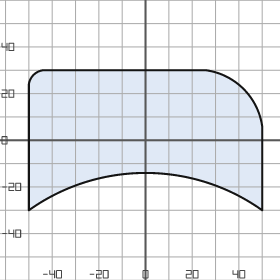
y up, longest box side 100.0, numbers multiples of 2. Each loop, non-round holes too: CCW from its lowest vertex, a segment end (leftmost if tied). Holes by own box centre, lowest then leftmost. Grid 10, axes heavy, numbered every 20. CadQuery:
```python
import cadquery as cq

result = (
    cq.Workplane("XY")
    .moveTo(-50.0, -30.0)
    .threePointArc((0.0, -14.0), (50.0, -30.0))
    .lineTo(50.0, 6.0)
    .threePointArc((42.0, 22.0), (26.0, 30.0))
    .lineTo(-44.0, 30.0)
    .threePointArc((-48.0, 28.0), (-50.0, 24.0))
    .close()
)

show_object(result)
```